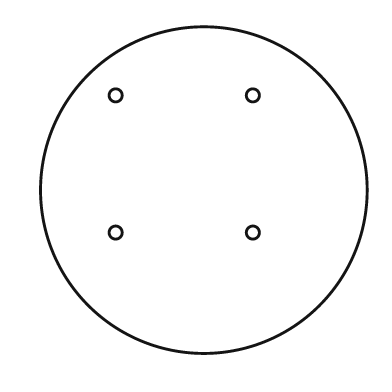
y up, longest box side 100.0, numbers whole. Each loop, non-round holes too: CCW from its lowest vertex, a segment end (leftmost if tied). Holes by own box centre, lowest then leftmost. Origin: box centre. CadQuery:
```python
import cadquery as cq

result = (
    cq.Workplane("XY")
    .moveTo(0.0, 0.0)
    .circle(50.0)
    .moveTo(-27.0, -13.0)
    .circle(2.0)
    .moveTo(15.0, -13.0)
    .circle(2.0)
    .moveTo(-27.0, 29.0)
    .circle(2.0)
    .moveTo(15.0, 29.0)
    .circle(2.0)
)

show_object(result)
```